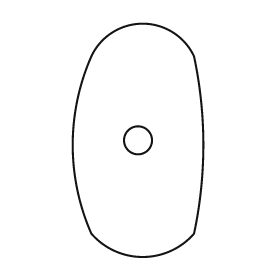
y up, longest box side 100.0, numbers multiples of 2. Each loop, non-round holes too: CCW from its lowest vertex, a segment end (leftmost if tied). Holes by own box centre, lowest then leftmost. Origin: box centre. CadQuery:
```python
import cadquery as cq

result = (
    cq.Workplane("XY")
    .moveTo(-20.0, -40.0)
    .threePointArc((2.0, -50.0), (24.0, -40.0))
    .threePointArc((28.0, -2.0), (24.0, 36.0))
    .threePointArc((2.0, 50.0), (-20.0, 36.0))
    .threePointArc((-28.0, -2.0), (-20.0, -40.0))
    .close()
    .moveTo(0.0, 0.0)
    .circle(6.0)
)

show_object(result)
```